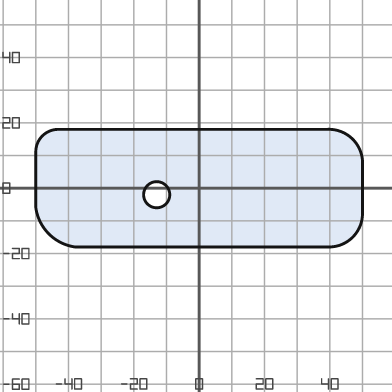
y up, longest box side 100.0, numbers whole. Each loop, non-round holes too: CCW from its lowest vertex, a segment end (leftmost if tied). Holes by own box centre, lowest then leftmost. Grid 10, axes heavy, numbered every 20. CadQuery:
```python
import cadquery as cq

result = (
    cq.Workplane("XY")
    .moveTo(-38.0, -18.0)
    .lineTo(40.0, -18.0)
    .threePointArc((47.0, -15.0), (50.0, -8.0))
    .lineTo(50.0, 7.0)
    .threePointArc((47.0, 15.0), (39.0, 18.0))
    .lineTo(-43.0, 18.0)
    .threePointArc((-48.0, 16.0), (-50.0, 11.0))
    .lineTo(-50.0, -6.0)
    .threePointArc((-46.0, -14.0), (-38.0, -18.0))
    .close()
    .moveTo(-13.0, -2.0)
    .circle(4.0)
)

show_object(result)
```